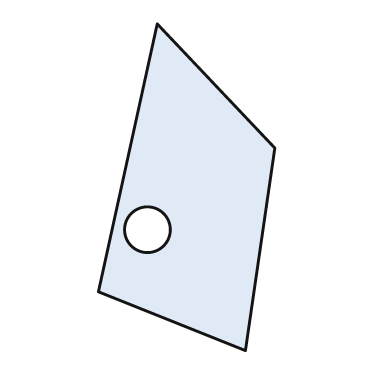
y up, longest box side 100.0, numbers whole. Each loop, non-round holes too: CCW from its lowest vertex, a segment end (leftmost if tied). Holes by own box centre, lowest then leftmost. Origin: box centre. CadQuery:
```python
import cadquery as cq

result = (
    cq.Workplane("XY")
    .moveTo(18.0, -50.0)
    .lineTo(27.0, 12.0)
    .lineTo(-9.0, 50.0)
    .lineTo(-27.0, -32.0)
    .close()
    .moveTo(-12.0, -13.0)
    .circle(7.0)
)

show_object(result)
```